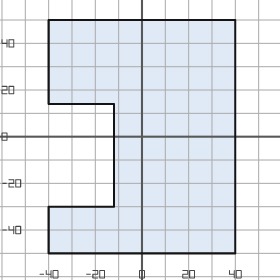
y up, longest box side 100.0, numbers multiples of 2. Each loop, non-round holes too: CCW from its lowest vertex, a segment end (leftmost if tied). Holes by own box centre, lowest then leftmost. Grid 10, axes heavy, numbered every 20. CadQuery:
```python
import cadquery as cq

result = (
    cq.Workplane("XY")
    .moveTo(-40.0, -50.0)
    .lineTo(40.0, -50.0)
    .lineTo(40.0, 50.0)
    .lineTo(-40.0, 50.0)
    .lineTo(-40.0, 14.0)
    .lineTo(-12.0, 14.0)
    .lineTo(-12.0, -30.0)
    .lineTo(-40.0, -30.0)
    .close()
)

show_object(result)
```